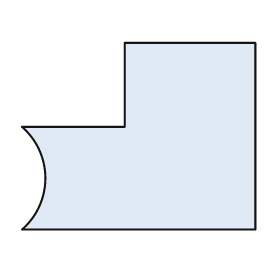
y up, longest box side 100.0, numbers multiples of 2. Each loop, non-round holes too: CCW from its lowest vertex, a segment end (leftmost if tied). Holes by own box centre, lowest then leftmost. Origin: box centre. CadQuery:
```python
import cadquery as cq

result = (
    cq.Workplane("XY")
    .moveTo(-50.0, -40.0)
    .lineTo(50.0, -40.0)
    .lineTo(50.0, 40.0)
    .lineTo(-6.0, 40.0)
    .lineTo(-6.0, 4.0)
    .lineTo(-50.0, 4.0)
    .threePointArc((-40.0, -18.0), (-50.0, -40.0))
    .close()
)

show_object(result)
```